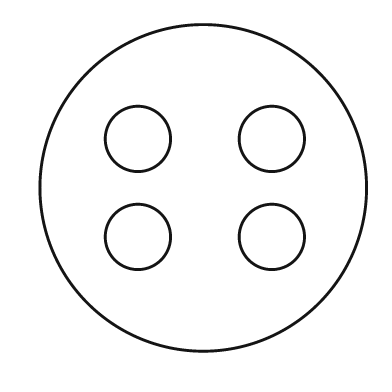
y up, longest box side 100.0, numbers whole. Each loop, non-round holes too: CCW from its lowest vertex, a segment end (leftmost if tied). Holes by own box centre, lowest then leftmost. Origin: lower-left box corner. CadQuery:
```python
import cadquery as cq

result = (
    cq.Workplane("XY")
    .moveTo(50.0, 50.0)
    .circle(50.0)
    .moveTo(30.0, 35.0)
    .circle(10.0)
    .moveTo(71.0, 35.0)
    .circle(10.0)
    .moveTo(30.0, 65.0)
    .circle(10.0)
    .moveTo(71.0, 65.0)
    .circle(10.0)
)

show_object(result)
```